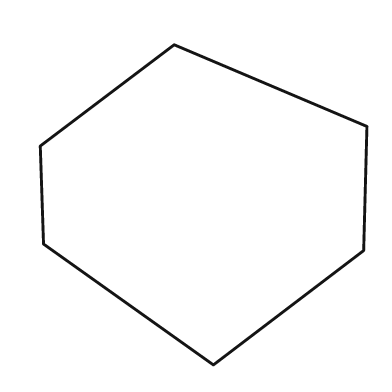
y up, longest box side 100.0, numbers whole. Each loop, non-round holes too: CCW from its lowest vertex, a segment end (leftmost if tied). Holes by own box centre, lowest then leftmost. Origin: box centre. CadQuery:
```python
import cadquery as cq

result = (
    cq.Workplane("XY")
    .moveTo(3.0, -49.0)
    .lineTo(49.0, -14.0)
    .lineTo(50.0, 24.0)
    .lineTo(-9.0, 49.0)
    .lineTo(-50.0, 18.0)
    .lineTo(-49.0, -12.0)
    .close()
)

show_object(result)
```